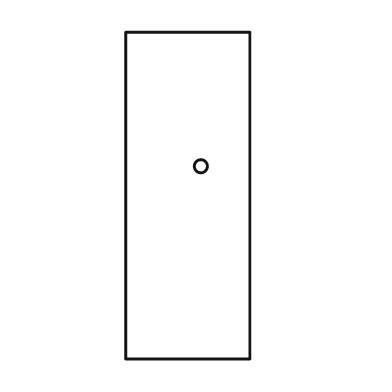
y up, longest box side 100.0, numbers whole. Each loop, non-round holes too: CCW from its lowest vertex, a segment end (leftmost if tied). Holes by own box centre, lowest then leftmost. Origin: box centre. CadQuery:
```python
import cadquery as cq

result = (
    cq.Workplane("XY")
    .moveTo(-19.0, -50.0)
    .lineTo(19.0, -50.0)
    .lineTo(19.0, 50.0)
    .lineTo(-19.0, 50.0)
    .close()
    .moveTo(4.0, 9.0)
    .circle(2.0)
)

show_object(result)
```